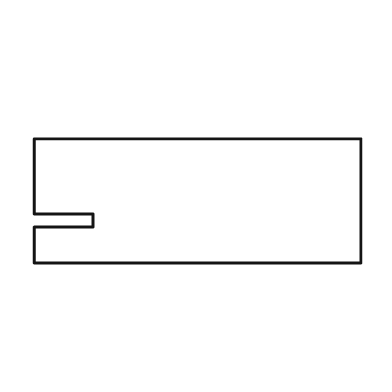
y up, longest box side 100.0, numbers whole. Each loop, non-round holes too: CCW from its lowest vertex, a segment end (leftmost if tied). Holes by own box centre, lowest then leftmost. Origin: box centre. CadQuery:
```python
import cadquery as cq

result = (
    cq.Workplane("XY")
    .moveTo(-50.0, -19.0)
    .lineTo(50.0, -19.0)
    .lineTo(50.0, 19.0)
    .lineTo(-50.0, 19.0)
    .lineTo(-50.0, -4.0)
    .lineTo(-32.0, -4.0)
    .lineTo(-32.0, -8.0)
    .lineTo(-50.0, -8.0)
    .close()
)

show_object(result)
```